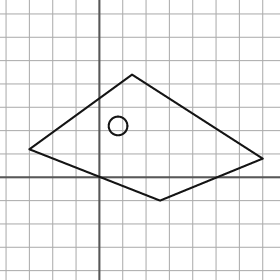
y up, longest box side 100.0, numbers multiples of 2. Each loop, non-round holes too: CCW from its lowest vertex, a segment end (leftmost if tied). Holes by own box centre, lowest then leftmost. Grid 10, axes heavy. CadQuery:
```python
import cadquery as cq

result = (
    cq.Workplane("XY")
    .moveTo(26.0, -10.0)
    .lineTo(70.0, 8.0)
    .lineTo(14.0, 44.0)
    .lineTo(-30.0, 12.0)
    .close()
    .moveTo(8.0, 22.0)
    .circle(4.0)
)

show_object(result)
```